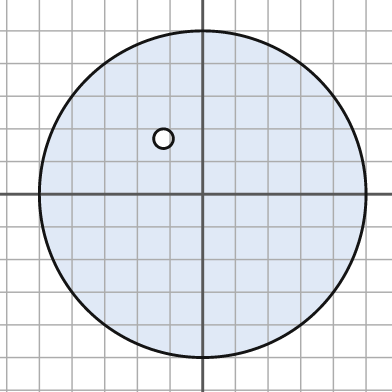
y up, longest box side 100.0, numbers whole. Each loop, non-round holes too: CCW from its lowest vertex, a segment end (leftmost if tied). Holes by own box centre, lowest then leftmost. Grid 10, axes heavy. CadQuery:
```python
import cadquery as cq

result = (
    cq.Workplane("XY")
    .moveTo(0.0, 0.0)
    .circle(50.0)
    .moveTo(-12.0, 17.0)
    .circle(3.0)
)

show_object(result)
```